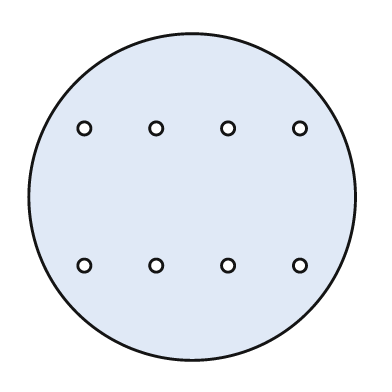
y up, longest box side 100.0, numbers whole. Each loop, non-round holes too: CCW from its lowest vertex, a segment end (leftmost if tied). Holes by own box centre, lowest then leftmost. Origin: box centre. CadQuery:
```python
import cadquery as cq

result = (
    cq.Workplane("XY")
    .moveTo(0.0, 0.0)
    .circle(50.0)
    .moveTo(-33.0, -21.0)
    .circle(2.0)
    .moveTo(-11.0, -21.0)
    .circle(2.0)
    .moveTo(11.0, -21.0)
    .circle(2.0)
    .moveTo(33.0, -21.0)
    .circle(2.0)
    .moveTo(-33.0, 21.0)
    .circle(2.0)
    .moveTo(-11.0, 21.0)
    .circle(2.0)
    .moveTo(11.0, 21.0)
    .circle(2.0)
    .moveTo(33.0, 21.0)
    .circle(2.0)
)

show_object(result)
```